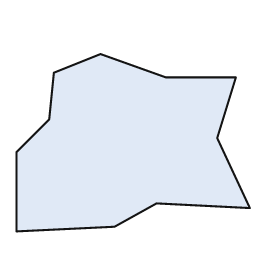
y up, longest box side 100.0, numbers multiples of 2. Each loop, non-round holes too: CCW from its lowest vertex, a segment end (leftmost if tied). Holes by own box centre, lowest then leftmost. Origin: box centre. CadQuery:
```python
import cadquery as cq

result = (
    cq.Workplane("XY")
    .moveTo(-50.0, -38.0)
    .lineTo(-8.0, -36.0)
    .lineTo(10.0, -26.0)
    .lineTo(50.0, -28.0)
    .lineTo(36.0, 2.0)
    .lineTo(44.0, 28.0)
    .lineTo(14.0, 28.0)
    .lineTo(-14.0, 38.0)
    .lineTo(-34.0, 30.0)
    .lineTo(-36.0, 10.0)
    .lineTo(-50.0, -4.0)
    .close()
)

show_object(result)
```